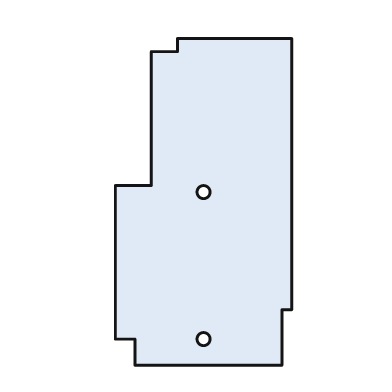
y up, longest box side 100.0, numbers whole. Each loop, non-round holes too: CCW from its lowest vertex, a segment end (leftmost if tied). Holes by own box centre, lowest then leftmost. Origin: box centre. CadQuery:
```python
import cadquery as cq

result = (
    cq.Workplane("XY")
    .moveTo(-21.0, -50.0)
    .lineTo(24.0, -50.0)
    .lineTo(24.0, -33.0)
    .lineTo(27.0, -33.0)
    .lineTo(27.0, 50.0)
    .lineTo(-8.0, 50.0)
    .lineTo(-8.0, 46.0)
    .lineTo(-16.0, 46.0)
    .lineTo(-16.0, 5.0)
    .lineTo(-27.0, 5.0)
    .lineTo(-27.0, -42.0)
    .lineTo(-21.0, -42.0)
    .close()
    .moveTo(0.0, -42.0)
    .circle(2.0)
    .moveTo(0.0, 3.0)
    .circle(2.0)
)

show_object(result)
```